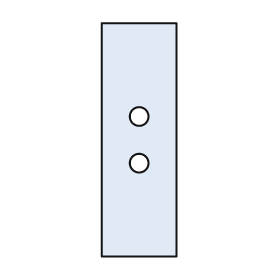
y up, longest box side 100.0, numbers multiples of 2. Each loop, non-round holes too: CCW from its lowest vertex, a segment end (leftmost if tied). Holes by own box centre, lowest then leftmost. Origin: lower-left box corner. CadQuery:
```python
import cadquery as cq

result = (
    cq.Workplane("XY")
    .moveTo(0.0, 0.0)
    .lineTo(32.0, 0.0)
    .lineTo(32.0, 100.0)
    .lineTo(0.0, 100.0)
    .close()
    .moveTo(16.0, 40.0)
    .circle(4.0)
    .moveTo(16.0, 60.0)
    .circle(4.0)
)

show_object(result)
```